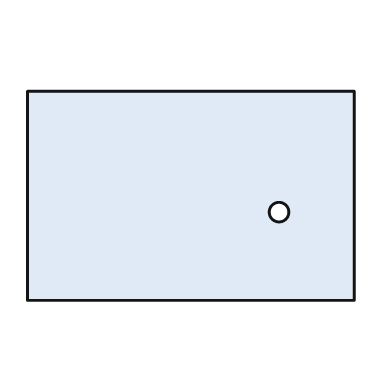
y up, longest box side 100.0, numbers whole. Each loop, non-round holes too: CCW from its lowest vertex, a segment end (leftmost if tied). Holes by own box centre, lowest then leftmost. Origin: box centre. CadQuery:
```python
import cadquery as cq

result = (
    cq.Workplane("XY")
    .moveTo(-50.0, -32.0)
    .lineTo(50.0, -32.0)
    .lineTo(50.0, 32.0)
    .lineTo(-50.0, 32.0)
    .close()
    .moveTo(27.0, -5.0)
    .circle(3.0)
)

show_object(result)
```